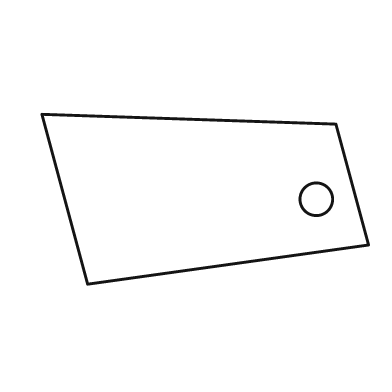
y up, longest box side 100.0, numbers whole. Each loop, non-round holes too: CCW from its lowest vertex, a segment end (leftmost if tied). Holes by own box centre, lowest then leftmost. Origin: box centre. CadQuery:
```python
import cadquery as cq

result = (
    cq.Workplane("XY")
    .moveTo(-36.0, -26.0)
    .lineTo(50.0, -14.0)
    .lineTo(40.0, 23.0)
    .lineTo(-50.0, 26.0)
    .close()
    .moveTo(34.0, 0.0)
    .circle(5.0)
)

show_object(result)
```